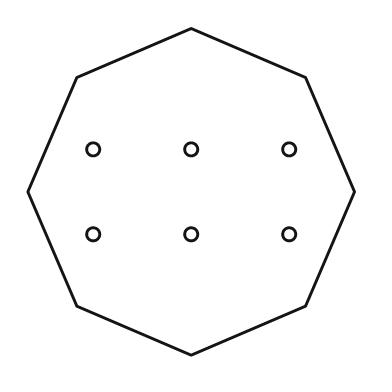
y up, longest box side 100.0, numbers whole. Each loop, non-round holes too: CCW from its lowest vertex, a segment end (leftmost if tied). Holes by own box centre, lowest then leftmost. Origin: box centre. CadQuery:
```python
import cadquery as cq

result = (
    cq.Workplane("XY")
    .moveTo(0.0, -50.0)
    .lineTo(35.0, -35.0)
    .lineTo(50.0, 0.0)
    .lineTo(35.0, 35.0)
    .lineTo(0.0, 50.0)
    .lineTo(-35.0, 35.0)
    .lineTo(-50.0, 0.0)
    .lineTo(-35.0, -35.0)
    .close()
    .moveTo(-30.0, -13.0)
    .circle(2.0)
    .moveTo(0.0, -13.0)
    .circle(2.0)
    .moveTo(30.0, -13.0)
    .circle(2.0)
    .moveTo(-30.0, 13.0)
    .circle(2.0)
    .moveTo(0.0, 13.0)
    .circle(2.0)
    .moveTo(30.0, 13.0)
    .circle(2.0)
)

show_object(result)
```